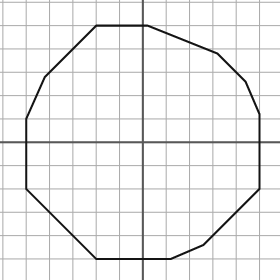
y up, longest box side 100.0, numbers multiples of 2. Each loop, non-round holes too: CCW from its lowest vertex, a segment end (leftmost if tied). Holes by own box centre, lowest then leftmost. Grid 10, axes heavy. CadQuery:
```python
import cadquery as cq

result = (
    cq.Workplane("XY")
    .moveTo(-20.0, -50.0)
    .lineTo(12.0, -50.0)
    .lineTo(26.0, -44.0)
    .lineTo(50.0, -20.0)
    .lineTo(50.0, 12.0)
    .lineTo(44.0, 26.0)
    .lineTo(32.0, 38.0)
    .lineTo(2.0, 50.0)
    .lineTo(-20.0, 50.0)
    .lineTo(-42.0, 28.0)
    .lineTo(-50.0, 10.0)
    .lineTo(-50.0, -20.0)
    .close()
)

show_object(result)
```